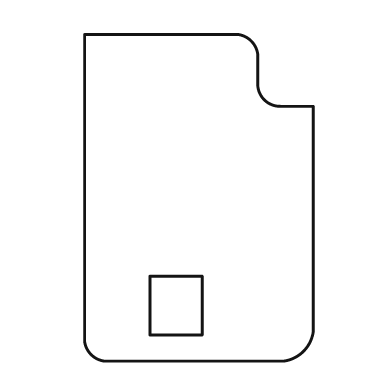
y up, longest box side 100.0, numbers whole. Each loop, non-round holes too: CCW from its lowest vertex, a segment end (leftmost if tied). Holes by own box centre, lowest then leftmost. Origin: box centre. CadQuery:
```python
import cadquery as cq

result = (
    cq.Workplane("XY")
    .moveTo(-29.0, -50.0)
    .lineTo(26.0, -50.0)
    .threePointArc((32.0, -47.0), (35.0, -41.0))
    .lineTo(35.0, 28.0)
    .lineTo(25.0, 28.0)
    .threePointArc((20.0, 30.0), (18.0, 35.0))
    .lineTo(18.0, 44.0)
    .threePointArc((16.0, 48.0), (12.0, 50.0))
    .lineTo(-35.0, 50.0)
    .lineTo(-35.0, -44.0)
    .threePointArc((-33.0, -48.0), (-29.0, -50.0))
    .close()
    .moveTo(-15.0, -42.0)
    .lineTo(1.0, -42.0)
    .lineTo(1.0, -24.0)
    .lineTo(-15.0, -24.0)
    .close()
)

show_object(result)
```